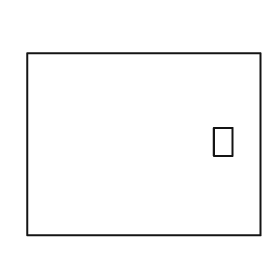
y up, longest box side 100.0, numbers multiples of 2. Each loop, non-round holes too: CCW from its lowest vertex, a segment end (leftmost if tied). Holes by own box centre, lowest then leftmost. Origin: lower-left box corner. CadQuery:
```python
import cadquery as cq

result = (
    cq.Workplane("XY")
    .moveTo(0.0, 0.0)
    .lineTo(100.0, 0.0)
    .lineTo(100.0, 78.0)
    .lineTo(0.0, 78.0)
    .close()
    .moveTo(80.0, 34.0)
    .lineTo(88.0, 34.0)
    .lineTo(88.0, 46.0)
    .lineTo(80.0, 46.0)
    .close()
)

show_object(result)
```